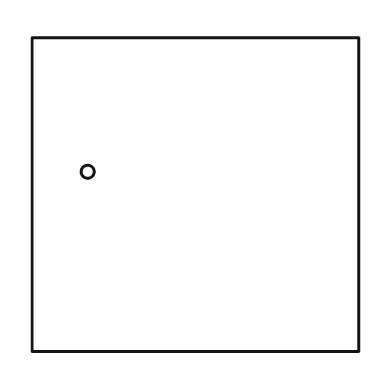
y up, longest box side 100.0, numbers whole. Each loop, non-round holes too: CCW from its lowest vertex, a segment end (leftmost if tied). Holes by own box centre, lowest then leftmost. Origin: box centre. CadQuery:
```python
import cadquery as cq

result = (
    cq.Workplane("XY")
    .moveTo(-50.0, -48.0)
    .lineTo(50.0, -48.0)
    .lineTo(50.0, 48.0)
    .lineTo(-50.0, 48.0)
    .close()
    .moveTo(-33.0, 7.0)
    .circle(2.0)
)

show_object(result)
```